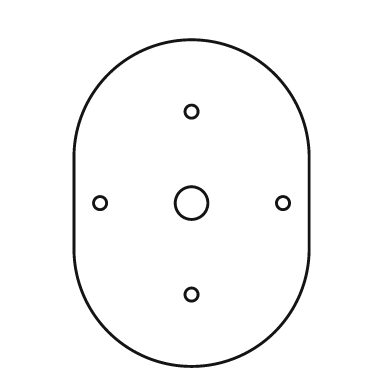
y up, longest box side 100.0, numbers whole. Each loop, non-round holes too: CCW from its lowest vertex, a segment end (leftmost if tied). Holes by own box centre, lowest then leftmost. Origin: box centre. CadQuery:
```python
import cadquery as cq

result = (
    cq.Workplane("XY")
    .moveTo(-36.0, -14.0)
    .threePointArc((0.0, -50.0), (36.0, -14.0))
    .lineTo(36.0, 14.0)
    .threePointArc((0.0, 50.0), (-36.0, 14.0))
    .close()
    .moveTo(0.0, -28.0)
    .circle(2.0)
    .moveTo(-28.0, 0.0)
    .circle(2.0)
    .moveTo(0.0, 0.0)
    .circle(5.0)
    .moveTo(28.0, 0.0)
    .circle(2.0)
    .moveTo(0.0, 28.0)
    .circle(2.0)
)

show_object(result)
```